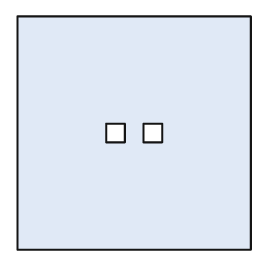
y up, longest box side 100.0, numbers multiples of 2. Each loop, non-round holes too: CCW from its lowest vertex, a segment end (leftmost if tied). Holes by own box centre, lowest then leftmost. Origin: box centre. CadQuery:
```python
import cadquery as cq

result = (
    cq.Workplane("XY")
    .moveTo(-50.0, -50.0)
    .lineTo(50.0, -50.0)
    .lineTo(50.0, 50.0)
    .lineTo(-50.0, 50.0)
    .close()
    .moveTo(-12.0, -4.0)
    .lineTo(-4.0, -4.0)
    .lineTo(-4.0, 4.0)
    .lineTo(-12.0, 4.0)
    .close()
    .moveTo(4.0, -4.0)
    .lineTo(12.0, -4.0)
    .lineTo(12.0, 4.0)
    .lineTo(4.0, 4.0)
    .close()
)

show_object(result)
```